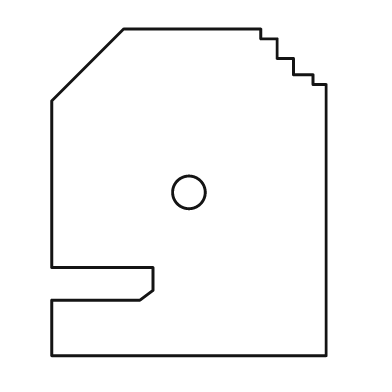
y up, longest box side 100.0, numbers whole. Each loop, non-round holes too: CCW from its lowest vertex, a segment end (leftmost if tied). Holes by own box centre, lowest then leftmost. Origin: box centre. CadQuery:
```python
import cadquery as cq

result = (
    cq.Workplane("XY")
    .moveTo(-42.0, -50.0)
    .lineTo(42.0, -50.0)
    .lineTo(42.0, 33.0)
    .lineTo(38.0, 33.0)
    .lineTo(38.0, 36.0)
    .lineTo(32.0, 36.0)
    .lineTo(32.0, 41.0)
    .lineTo(27.0, 41.0)
    .lineTo(27.0, 47.0)
    .lineTo(22.0, 47.0)
    .lineTo(22.0, 50.0)
    .lineTo(-20.0, 50.0)
    .lineTo(-42.0, 28.0)
    .lineTo(-42.0, -23.0)
    .lineTo(-11.0, -23.0)
    .lineTo(-11.0, -30.0)
    .lineTo(-15.0, -33.0)
    .lineTo(-42.0, -33.0)
    .close()
    .moveTo(0.0, 0.0)
    .circle(5.0)
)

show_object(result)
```